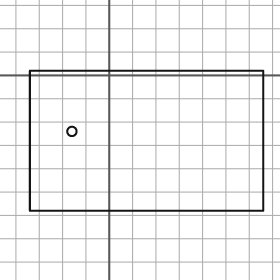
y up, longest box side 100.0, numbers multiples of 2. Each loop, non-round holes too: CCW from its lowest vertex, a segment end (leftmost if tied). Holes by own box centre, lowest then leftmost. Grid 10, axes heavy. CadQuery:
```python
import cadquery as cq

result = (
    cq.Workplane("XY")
    .moveTo(-34.0, -58.0)
    .lineTo(66.0, -58.0)
    .lineTo(66.0, 2.0)
    .lineTo(-34.0, 2.0)
    .close()
    .moveTo(-16.0, -24.0)
    .circle(2.0)
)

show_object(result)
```